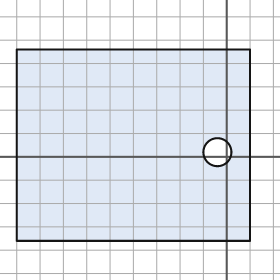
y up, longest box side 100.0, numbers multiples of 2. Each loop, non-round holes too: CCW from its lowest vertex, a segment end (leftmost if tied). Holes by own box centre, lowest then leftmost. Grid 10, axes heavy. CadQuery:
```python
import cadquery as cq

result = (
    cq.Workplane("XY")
    .moveTo(-90.0, -36.0)
    .lineTo(10.0, -36.0)
    .lineTo(10.0, 46.0)
    .lineTo(-90.0, 46.0)
    .close()
    .moveTo(-4.0, 2.0)
    .circle(6.0)
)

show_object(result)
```